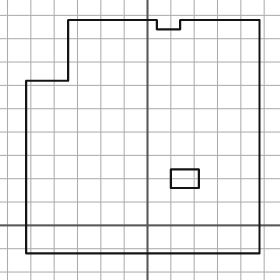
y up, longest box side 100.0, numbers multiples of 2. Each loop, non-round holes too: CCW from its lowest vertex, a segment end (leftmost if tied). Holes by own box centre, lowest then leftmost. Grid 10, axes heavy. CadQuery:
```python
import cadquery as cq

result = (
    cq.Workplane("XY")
    .moveTo(-52.0, -12.0)
    .lineTo(48.0, -12.0)
    .lineTo(48.0, 88.0)
    .lineTo(14.0, 88.0)
    .lineTo(14.0, 84.0)
    .lineTo(4.0, 84.0)
    .lineTo(4.0, 88.0)
    .lineTo(-34.0, 88.0)
    .lineTo(-34.0, 62.0)
    .lineTo(-52.0, 62.0)
    .close()
    .moveTo(10.0, 16.0)
    .lineTo(22.0, 16.0)
    .lineTo(22.0, 24.0)
    .lineTo(10.0, 24.0)
    .close()
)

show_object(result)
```